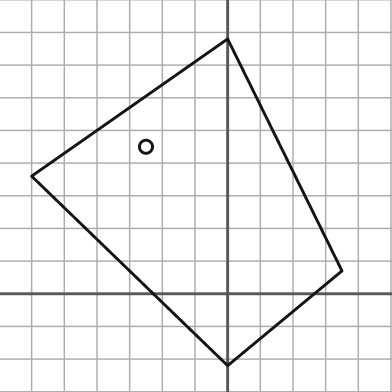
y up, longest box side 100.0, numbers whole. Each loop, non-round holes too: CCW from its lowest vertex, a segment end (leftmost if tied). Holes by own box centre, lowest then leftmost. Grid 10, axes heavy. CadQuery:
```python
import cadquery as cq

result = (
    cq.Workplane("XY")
    .moveTo(0.0, -22.0)
    .lineTo(35.0, 7.0)
    .lineTo(0.0, 78.0)
    .lineTo(-60.0, 36.0)
    .close()
    .moveTo(-25.0, 45.0)
    .circle(2.0)
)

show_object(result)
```